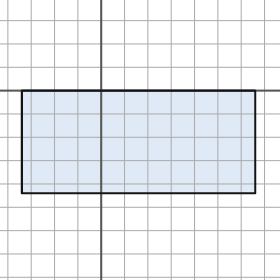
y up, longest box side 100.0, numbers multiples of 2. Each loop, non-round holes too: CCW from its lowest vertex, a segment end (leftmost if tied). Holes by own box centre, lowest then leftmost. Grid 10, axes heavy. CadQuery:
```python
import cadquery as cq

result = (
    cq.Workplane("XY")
    .moveTo(-34.0, -44.0)
    .lineTo(66.0, -44.0)
    .lineTo(66.0, 0.0)
    .lineTo(-34.0, 0.0)
    .close()
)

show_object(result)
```